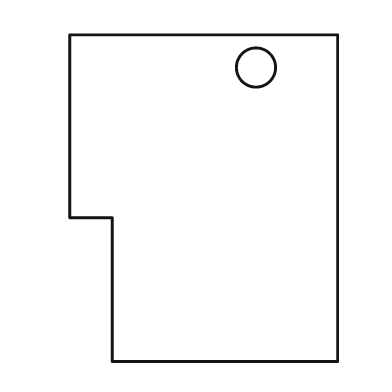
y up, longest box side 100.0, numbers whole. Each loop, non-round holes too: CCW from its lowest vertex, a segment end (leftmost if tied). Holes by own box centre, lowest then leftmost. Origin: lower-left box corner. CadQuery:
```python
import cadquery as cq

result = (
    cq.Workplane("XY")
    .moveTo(13.0, 0.0)
    .lineTo(82.0, 0.0)
    .lineTo(82.0, 100.0)
    .lineTo(0.0, 100.0)
    .lineTo(0.0, 44.0)
    .lineTo(13.0, 44.0)
    .close()
    .moveTo(57.0, 90.0)
    .circle(6.0)
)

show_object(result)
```